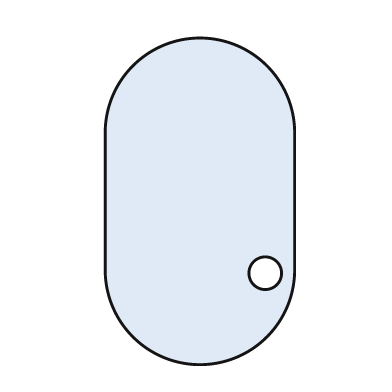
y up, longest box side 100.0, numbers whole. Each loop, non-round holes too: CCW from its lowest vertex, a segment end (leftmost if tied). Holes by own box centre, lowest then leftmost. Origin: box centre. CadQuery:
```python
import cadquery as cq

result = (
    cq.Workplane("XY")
    .moveTo(-29.0, -21.0)
    .threePointArc((0.0, -50.0), (29.0, -21.0))
    .lineTo(29.0, 21.0)
    .threePointArc((0.0, 50.0), (-29.0, 21.0))
    .close()
    .moveTo(20.0, -22.0)
    .circle(5.0)
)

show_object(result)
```